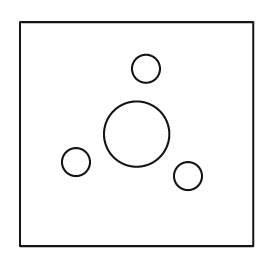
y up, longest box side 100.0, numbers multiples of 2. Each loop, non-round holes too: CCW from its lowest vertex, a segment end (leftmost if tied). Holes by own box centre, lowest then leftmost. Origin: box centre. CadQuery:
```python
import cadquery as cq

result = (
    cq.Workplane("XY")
    .moveTo(-50.0, -48.0)
    .lineTo(50.0, -48.0)
    .lineTo(50.0, 48.0)
    .lineTo(-50.0, 48.0)
    .close()
    .moveTo(22.0, -18.0)
    .circle(6.0)
    .moveTo(-26.0, -12.0)
    .circle(6.0)
    .moveTo(0.0, 0.0)
    .circle(14.0)
    .moveTo(4.0, 28.0)
    .circle(6.0)
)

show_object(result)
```